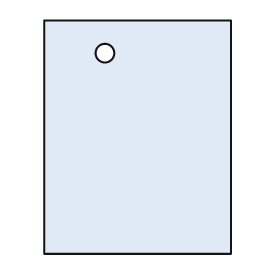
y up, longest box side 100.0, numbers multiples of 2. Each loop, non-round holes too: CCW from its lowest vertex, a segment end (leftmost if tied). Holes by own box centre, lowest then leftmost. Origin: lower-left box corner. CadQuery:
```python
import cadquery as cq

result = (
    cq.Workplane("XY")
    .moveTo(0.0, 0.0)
    .lineTo(80.0, 0.0)
    .lineTo(80.0, 100.0)
    .lineTo(0.0, 100.0)
    .close()
    .moveTo(26.0, 86.0)
    .circle(4.0)
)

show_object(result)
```